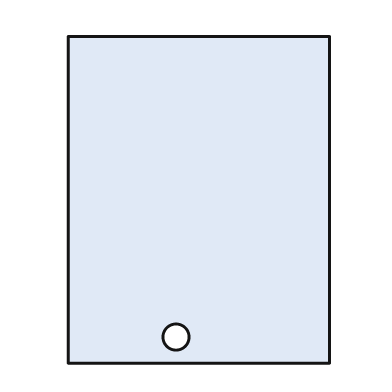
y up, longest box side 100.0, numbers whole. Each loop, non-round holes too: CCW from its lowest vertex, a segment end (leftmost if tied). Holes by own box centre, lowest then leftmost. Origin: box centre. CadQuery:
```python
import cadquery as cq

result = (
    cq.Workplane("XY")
    .moveTo(-40.0, -50.0)
    .lineTo(40.0, -50.0)
    .lineTo(40.0, 50.0)
    .lineTo(-40.0, 50.0)
    .close()
    .moveTo(-7.0, -42.0)
    .circle(4.0)
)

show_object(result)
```